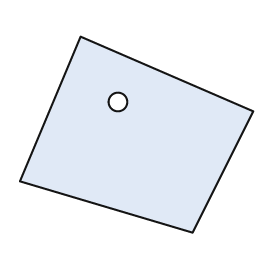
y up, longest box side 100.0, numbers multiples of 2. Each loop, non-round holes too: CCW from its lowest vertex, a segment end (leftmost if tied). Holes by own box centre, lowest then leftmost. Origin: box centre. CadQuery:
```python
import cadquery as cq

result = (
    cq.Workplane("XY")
    .moveTo(24.0, -42.0)
    .lineTo(50.0, 10.0)
    .lineTo(-24.0, 42.0)
    .lineTo(-50.0, -20.0)
    .close()
    .moveTo(-8.0, 14.0)
    .circle(4.0)
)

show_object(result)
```